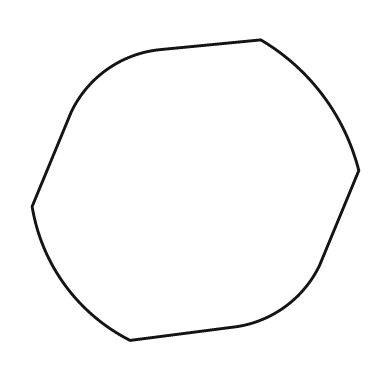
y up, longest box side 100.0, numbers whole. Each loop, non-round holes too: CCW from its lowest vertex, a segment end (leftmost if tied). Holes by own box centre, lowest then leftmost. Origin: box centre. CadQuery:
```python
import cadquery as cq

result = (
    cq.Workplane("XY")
    .moveTo(-20.0, -46.0)
    .lineTo(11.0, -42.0)
    .threePointArc((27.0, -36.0), (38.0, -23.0))
    .lineTo(50.0, 6.0)
    .threePointArc((39.0, 29.0), (20.0, 46.0))
    .lineTo(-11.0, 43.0)
    .threePointArc((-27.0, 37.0), (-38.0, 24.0))
    .lineTo(-50.0, -5.0)
    .threePointArc((-40.0, -29.0), (-20.0, -46.0))
    .close()
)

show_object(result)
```